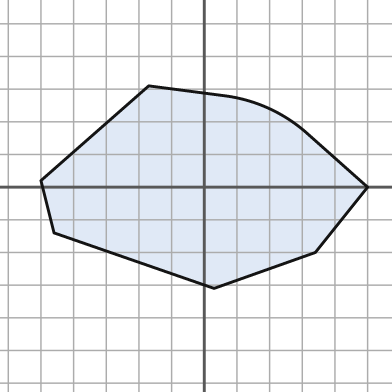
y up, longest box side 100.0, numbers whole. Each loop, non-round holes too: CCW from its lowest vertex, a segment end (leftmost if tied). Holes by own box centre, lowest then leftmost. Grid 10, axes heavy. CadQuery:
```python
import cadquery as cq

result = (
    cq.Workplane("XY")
    .moveTo(3.0, -31.0)
    .lineTo(34.0, -20.0)
    .lineTo(50.0, 0.0)
    .lineTo(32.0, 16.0)
    .threePointArc((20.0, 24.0), (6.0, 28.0))
    .lineTo(-17.0, 31.0)
    .lineTo(-50.0, 2.0)
    .lineTo(-46.0, -14.0)
    .close()
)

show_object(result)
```